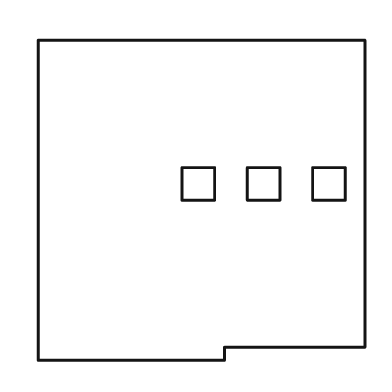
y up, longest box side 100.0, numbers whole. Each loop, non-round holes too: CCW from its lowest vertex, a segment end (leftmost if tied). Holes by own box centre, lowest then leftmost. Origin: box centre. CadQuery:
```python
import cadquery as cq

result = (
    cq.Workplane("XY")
    .moveTo(-50.0, -49.0)
    .lineTo(7.0, -49.0)
    .lineTo(7.0, -45.0)
    .lineTo(50.0, -45.0)
    .lineTo(50.0, 49.0)
    .lineTo(-50.0, 49.0)
    .close()
    .moveTo(-6.0, 0.0)
    .lineTo(4.0, 0.0)
    .lineTo(4.0, 10.0)
    .lineTo(-6.0, 10.0)
    .close()
    .moveTo(14.0, 0.0)
    .lineTo(24.0, 0.0)
    .lineTo(24.0, 10.0)
    .lineTo(14.0, 10.0)
    .close()
    .moveTo(34.0, 0.0)
    .lineTo(44.0, 0.0)
    .lineTo(44.0, 10.0)
    .lineTo(34.0, 10.0)
    .close()
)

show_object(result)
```